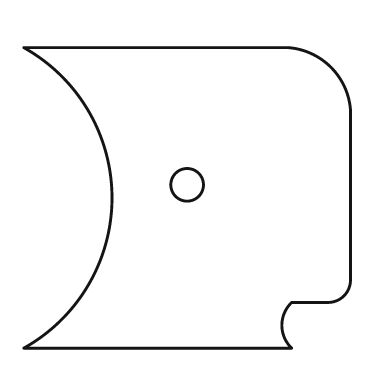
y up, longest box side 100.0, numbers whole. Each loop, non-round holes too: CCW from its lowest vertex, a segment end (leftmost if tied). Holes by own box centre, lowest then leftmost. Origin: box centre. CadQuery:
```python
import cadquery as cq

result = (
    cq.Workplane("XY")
    .moveTo(-50.0, -46.0)
    .lineTo(32.0, -46.0)
    .threePointArc((29.0, -39.0), (32.0, -32.0))
    .lineTo(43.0, -32.0)
    .threePointArc((48.0, -30.0), (50.0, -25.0))
    .lineTo(50.0, 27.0)
    .threePointArc((44.0, 40.0), (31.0, 46.0))
    .lineTo(-50.0, 46.0)
    .threePointArc((-23.0, 0.0), (-50.0, -46.0))
    .close()
    .moveTo(0.0, 4.0)
    .circle(5.0)
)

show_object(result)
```